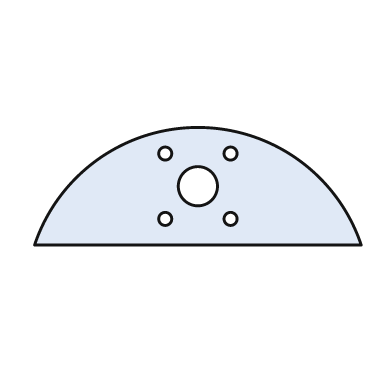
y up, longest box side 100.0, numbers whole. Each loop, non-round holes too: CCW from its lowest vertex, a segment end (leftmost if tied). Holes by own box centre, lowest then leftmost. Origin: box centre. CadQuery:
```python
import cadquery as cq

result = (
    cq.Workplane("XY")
    .moveTo(-50.0, -18.0)
    .lineTo(50.0, -18.0)
    .threePointArc((0.0, 18.0), (-50.0, -18.0))
    .close()
    .moveTo(-10.0, -10.0)
    .circle(2.0)
    .moveTo(10.0, -10.0)
    .circle(2.0)
    .moveTo(0.0, 0.0)
    .circle(6.0)
    .moveTo(-10.0, 10.0)
    .circle(2.0)
    .moveTo(10.0, 10.0)
    .circle(2.0)
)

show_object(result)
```